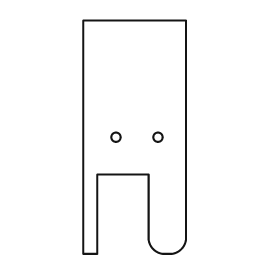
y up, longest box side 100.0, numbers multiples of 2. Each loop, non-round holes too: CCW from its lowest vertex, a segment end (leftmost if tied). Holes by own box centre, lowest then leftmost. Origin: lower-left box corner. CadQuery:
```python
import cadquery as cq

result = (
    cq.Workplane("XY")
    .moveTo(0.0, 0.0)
    .lineTo(6.0, 0.0)
    .lineTo(6.0, 34.0)
    .lineTo(28.0, 34.0)
    .lineTo(28.0, 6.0)
    .threePointArc((30.0, 2.0), (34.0, 0.0))
    .lineTo(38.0, 0.0)
    .threePointArc((42.0, 2.0), (44.0, 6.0))
    .lineTo(44.0, 100.0)
    .lineTo(0.0, 100.0)
    .close()
    .moveTo(14.0, 50.0)
    .circle(2.0)
    .moveTo(32.0, 50.0)
    .circle(2.0)
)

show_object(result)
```